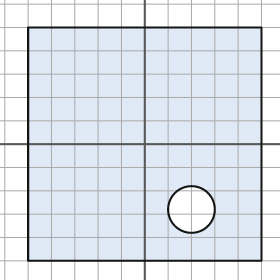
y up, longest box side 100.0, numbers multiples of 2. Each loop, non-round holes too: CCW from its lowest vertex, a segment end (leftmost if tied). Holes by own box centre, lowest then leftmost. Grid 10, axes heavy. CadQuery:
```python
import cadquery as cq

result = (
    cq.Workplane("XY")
    .moveTo(-50.0, -50.0)
    .lineTo(50.0, -50.0)
    .lineTo(50.0, 50.0)
    .lineTo(-50.0, 50.0)
    .close()
    .moveTo(20.0, -28.0)
    .circle(10.0)
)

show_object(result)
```